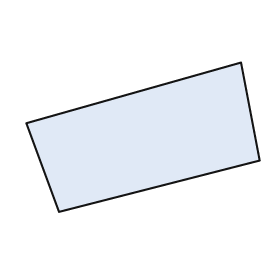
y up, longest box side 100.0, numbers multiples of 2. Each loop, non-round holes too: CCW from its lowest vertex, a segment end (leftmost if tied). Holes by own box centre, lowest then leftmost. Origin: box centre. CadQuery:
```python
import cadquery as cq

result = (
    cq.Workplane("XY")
    .moveTo(-36.0, -32.0)
    .lineTo(50.0, -10.0)
    .lineTo(42.0, 32.0)
    .lineTo(-50.0, 6.0)
    .close()
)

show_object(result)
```